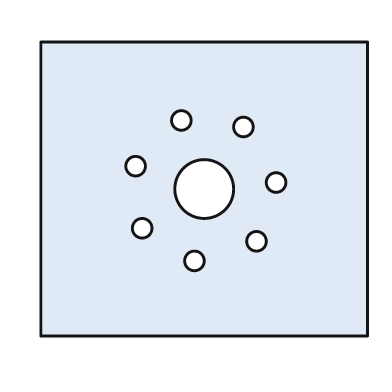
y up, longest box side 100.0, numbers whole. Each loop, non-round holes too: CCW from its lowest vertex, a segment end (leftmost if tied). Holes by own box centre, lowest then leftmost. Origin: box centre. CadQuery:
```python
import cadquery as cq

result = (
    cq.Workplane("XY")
    .moveTo(-50.0, -45.0)
    .lineTo(50.0, -45.0)
    .lineTo(50.0, 45.0)
    .lineTo(-50.0, 45.0)
    .close()
    .moveTo(-3.0, -22.0)
    .circle(3.0)
    .moveTo(16.0, -16.0)
    .circle(3.0)
    .moveTo(-19.0, -12.0)
    .circle(3.0)
    .moveTo(0.0, 0.0)
    .circle(9.0)
    .moveTo(22.0, 2.0)
    .circle(3.0)
    .moveTo(-21.0, 7.0)
    .circle(3.0)
    .moveTo(12.0, 19.0)
    .circle(3.0)
    .moveTo(-7.0, 21.0)
    .circle(3.0)
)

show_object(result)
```